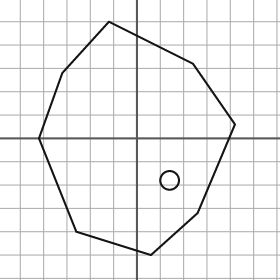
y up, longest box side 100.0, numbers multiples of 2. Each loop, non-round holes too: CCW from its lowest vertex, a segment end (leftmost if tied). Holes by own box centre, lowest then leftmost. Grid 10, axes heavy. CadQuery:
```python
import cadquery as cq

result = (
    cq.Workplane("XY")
    .moveTo(6.0, -50.0)
    .lineTo(26.0, -32.0)
    .lineTo(42.0, 6.0)
    .lineTo(24.0, 32.0)
    .lineTo(-12.0, 50.0)
    .lineTo(-32.0, 28.0)
    .lineTo(-42.0, 0.0)
    .lineTo(-26.0, -40.0)
    .close()
    .moveTo(14.0, -18.0)
    .circle(4.0)
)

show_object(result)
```